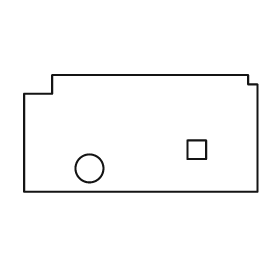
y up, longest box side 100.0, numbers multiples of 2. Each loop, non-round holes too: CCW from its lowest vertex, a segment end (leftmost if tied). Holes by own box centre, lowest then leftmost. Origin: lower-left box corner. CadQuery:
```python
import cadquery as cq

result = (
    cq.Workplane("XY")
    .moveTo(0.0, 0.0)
    .lineTo(100.0, 0.0)
    .lineTo(100.0, 46.0)
    .lineTo(96.0, 46.0)
    .lineTo(96.0, 50.0)
    .lineTo(12.0, 50.0)
    .lineTo(12.0, 42.0)
    .lineTo(0.0, 42.0)
    .close()
    .moveTo(28.0, 10.0)
    .circle(6.0)
    .moveTo(70.0, 14.0)
    .lineTo(78.0, 14.0)
    .lineTo(78.0, 22.0)
    .lineTo(70.0, 22.0)
    .close()
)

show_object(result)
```